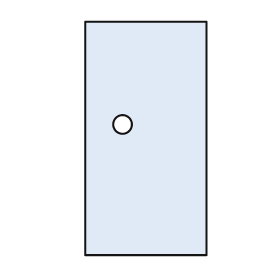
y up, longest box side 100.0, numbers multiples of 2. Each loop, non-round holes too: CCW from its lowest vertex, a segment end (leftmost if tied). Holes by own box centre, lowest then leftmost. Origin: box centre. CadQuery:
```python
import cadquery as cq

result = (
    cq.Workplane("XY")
    .moveTo(-26.0, -50.0)
    .lineTo(26.0, -50.0)
    .lineTo(26.0, 50.0)
    .lineTo(-26.0, 50.0)
    .close()
    .moveTo(-10.0, 6.0)
    .circle(4.0)
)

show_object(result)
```